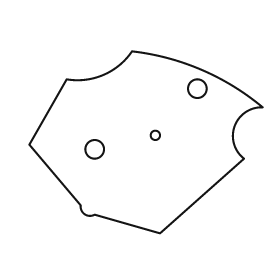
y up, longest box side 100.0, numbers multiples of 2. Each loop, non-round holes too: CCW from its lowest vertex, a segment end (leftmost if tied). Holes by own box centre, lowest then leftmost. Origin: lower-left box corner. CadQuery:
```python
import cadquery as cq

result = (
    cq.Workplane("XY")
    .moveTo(56.0, 0.0)
    .lineTo(92.0, 32.0)
    .threePointArc((88.0, 46.0), (100.0, 54.0))
    .threePointArc((74.0, 70.0), (44.0, 78.0))
    .threePointArc((32.0, 68.0), (16.0, 66.0))
    .lineTo(0.0, 38.0)
    .lineTo(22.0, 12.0)
    .threePointArc((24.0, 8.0), (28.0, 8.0))
    .close()
    .moveTo(28.0, 36.0)
    .circle(4.0)
    .moveTo(54.0, 42.0)
    .circle(2.0)
    .moveTo(72.0, 62.0)
    .circle(4.0)
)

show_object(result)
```